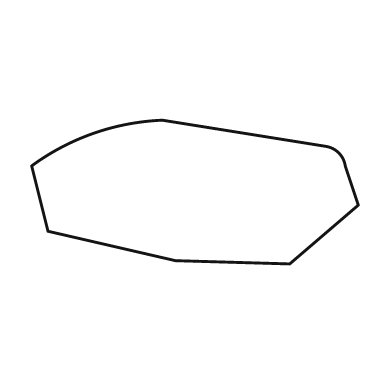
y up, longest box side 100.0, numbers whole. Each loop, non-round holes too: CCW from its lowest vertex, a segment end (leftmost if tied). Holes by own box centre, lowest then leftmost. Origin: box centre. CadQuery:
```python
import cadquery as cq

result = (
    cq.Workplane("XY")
    .moveTo(29.0, -22.0)
    .lineTo(50.0, -4.0)
    .lineTo(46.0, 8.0)
    .threePointArc((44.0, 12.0), (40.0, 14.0))
    .lineTo(-10.0, 22.0)
    .threePointArc((-31.0, 18.0), (-50.0, 8.0))
    .lineTo(-45.0, -12.0)
    .lineTo(-6.0, -21.0)
    .close()
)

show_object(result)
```